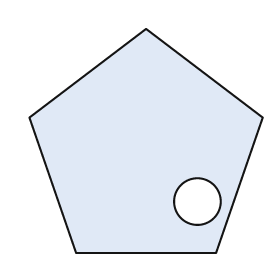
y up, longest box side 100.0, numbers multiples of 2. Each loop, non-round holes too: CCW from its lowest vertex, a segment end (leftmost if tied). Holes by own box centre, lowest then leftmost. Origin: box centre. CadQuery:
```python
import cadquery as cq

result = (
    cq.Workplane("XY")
    .moveTo(-30.0, -48.0)
    .lineTo(30.0, -48.0)
    .lineTo(50.0, 10.0)
    .lineTo(0.0, 48.0)
    .lineTo(-50.0, 10.0)
    .close()
    .moveTo(22.0, -26.0)
    .circle(10.0)
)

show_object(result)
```